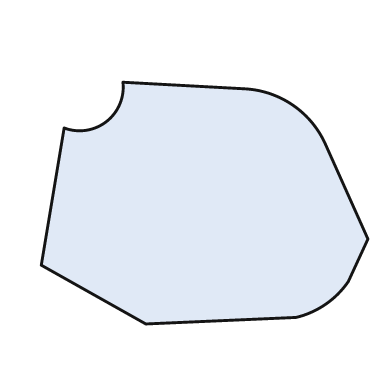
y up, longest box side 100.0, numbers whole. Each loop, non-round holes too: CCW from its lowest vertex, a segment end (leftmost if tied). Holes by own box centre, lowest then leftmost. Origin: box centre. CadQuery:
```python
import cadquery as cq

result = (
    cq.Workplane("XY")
    .moveTo(-18.0, -37.0)
    .lineTo(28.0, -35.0)
    .threePointArc((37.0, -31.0), (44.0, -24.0))
    .lineTo(50.0, -11.0)
    .lineTo(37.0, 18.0)
    .threePointArc((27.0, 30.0), (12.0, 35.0))
    .lineTo(-25.0, 37.0)
    .threePointArc((-30.0, 25.0), (-43.0, 23.0))
    .lineTo(-50.0, -19.0)
    .close()
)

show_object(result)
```